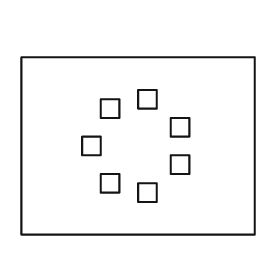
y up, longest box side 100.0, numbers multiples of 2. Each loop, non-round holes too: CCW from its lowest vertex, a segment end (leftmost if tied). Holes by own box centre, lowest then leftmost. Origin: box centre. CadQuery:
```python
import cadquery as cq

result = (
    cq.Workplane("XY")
    .moveTo(-50.0, -38.0)
    .lineTo(50.0, -38.0)
    .lineTo(50.0, 38.0)
    .lineTo(-50.0, 38.0)
    .close()
    .moveTo(0.0, -24.0)
    .lineTo(8.0, -24.0)
    .lineTo(8.0, -16.0)
    .lineTo(0.0, -16.0)
    .close()
    .moveTo(-16.0, -20.0)
    .lineTo(-8.0, -20.0)
    .lineTo(-8.0, -12.0)
    .lineTo(-16.0, -12.0)
    .close()
    .moveTo(14.0, -12.0)
    .lineTo(22.0, -12.0)
    .lineTo(22.0, -4.0)
    .lineTo(14.0, -4.0)
    .close()
    .moveTo(-24.0, -4.0)
    .lineTo(-16.0, -4.0)
    .lineTo(-16.0, 4.0)
    .lineTo(-24.0, 4.0)
    .close()
    .moveTo(14.0, 4.0)
    .lineTo(22.0, 4.0)
    .lineTo(22.0, 12.0)
    .lineTo(14.0, 12.0)
    .close()
    .moveTo(-16.0, 12.0)
    .lineTo(-8.0, 12.0)
    .lineTo(-8.0, 20.0)
    .lineTo(-16.0, 20.0)
    .close()
    .moveTo(0.0, 16.0)
    .lineTo(8.0, 16.0)
    .lineTo(8.0, 24.0)
    .lineTo(0.0, 24.0)
    .close()
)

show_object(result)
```